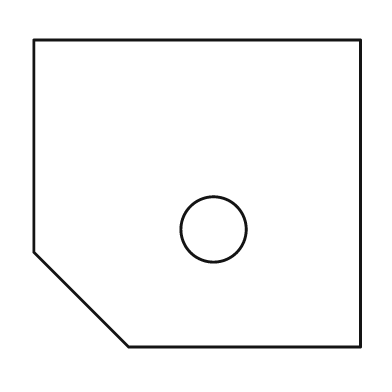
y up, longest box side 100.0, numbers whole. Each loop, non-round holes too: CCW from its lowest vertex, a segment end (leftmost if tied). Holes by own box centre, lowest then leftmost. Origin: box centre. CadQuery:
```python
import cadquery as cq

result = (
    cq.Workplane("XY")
    .moveTo(-21.0, -47.0)
    .lineTo(50.0, -47.0)
    .lineTo(50.0, 47.0)
    .lineTo(-50.0, 47.0)
    .lineTo(-50.0, -18.0)
    .close()
    .moveTo(5.0, -11.0)
    .circle(10.0)
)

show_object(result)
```